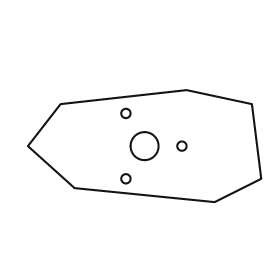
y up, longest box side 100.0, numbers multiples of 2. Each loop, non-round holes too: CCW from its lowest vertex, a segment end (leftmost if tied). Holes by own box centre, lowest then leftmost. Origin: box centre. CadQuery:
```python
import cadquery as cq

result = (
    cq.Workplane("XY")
    .moveTo(30.0, -24.0)
    .lineTo(50.0, -14.0)
    .lineTo(46.0, 18.0)
    .lineTo(18.0, 24.0)
    .lineTo(-36.0, 18.0)
    .lineTo(-50.0, 0.0)
    .lineTo(-30.0, -18.0)
    .close()
    .moveTo(-8.0, -14.0)
    .circle(2.0)
    .moveTo(0.0, 0.0)
    .circle(6.0)
    .moveTo(16.0, 0.0)
    .circle(2.0)
    .moveTo(-8.0, 14.0)
    .circle(2.0)
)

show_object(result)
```